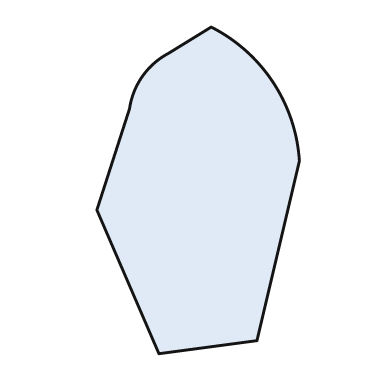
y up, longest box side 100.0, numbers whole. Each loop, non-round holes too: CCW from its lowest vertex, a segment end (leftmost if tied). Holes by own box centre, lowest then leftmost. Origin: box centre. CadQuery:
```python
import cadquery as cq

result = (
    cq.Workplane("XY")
    .moveTo(-12.0, -50.0)
    .lineTo(18.0, -46.0)
    .lineTo(31.0, 9.0)
    .threePointArc((23.0, 33.0), (4.0, 50.0))
    .lineTo(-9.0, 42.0)
    .threePointArc((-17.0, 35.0), (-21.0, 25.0))
    .lineTo(-31.0, -6.0)
    .close()
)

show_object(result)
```